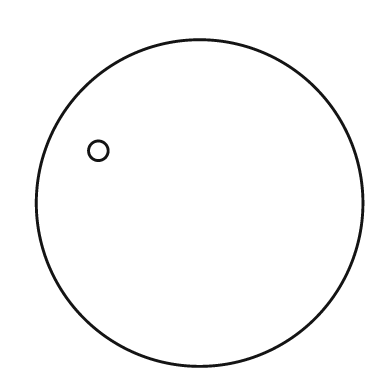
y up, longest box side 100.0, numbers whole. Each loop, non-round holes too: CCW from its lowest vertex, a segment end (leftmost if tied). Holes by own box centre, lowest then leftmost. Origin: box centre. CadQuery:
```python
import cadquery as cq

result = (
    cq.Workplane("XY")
    .moveTo(0.0, 0.0)
    .circle(50.0)
    .moveTo(-31.0, 16.0)
    .circle(3.0)
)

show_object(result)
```